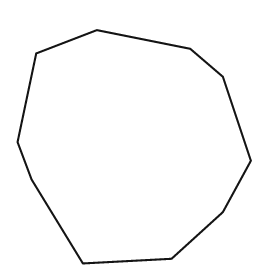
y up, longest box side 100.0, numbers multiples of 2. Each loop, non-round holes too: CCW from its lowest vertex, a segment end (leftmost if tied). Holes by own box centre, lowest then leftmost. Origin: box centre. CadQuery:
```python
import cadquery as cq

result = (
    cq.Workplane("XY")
    .moveTo(-22.0, -50.0)
    .lineTo(16.0, -48.0)
    .lineTo(38.0, -28.0)
    .lineTo(50.0, -6.0)
    .lineTo(38.0, 30.0)
    .lineTo(24.0, 42.0)
    .lineTo(-16.0, 50.0)
    .lineTo(-42.0, 40.0)
    .lineTo(-50.0, 2.0)
    .lineTo(-44.0, -14.0)
    .close()
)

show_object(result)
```